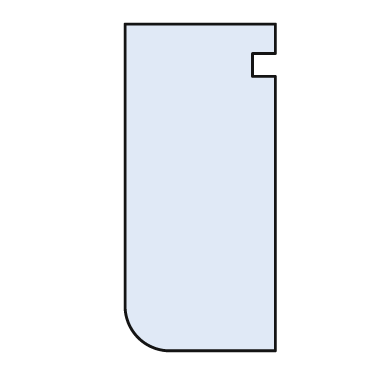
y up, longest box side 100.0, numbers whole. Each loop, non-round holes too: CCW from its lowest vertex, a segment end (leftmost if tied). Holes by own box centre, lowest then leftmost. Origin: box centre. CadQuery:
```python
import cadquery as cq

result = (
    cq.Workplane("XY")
    .moveTo(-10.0, -50.0)
    .lineTo(23.0, -50.0)
    .lineTo(23.0, 34.0)
    .lineTo(16.0, 34.0)
    .lineTo(16.0, 41.0)
    .lineTo(23.0, 41.0)
    .lineTo(23.0, 50.0)
    .lineTo(-23.0, 50.0)
    .lineTo(-23.0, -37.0)
    .threePointArc((-19.0, -46.0), (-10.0, -50.0))
    .close()
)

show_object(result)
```